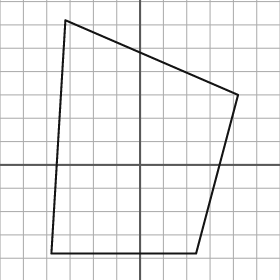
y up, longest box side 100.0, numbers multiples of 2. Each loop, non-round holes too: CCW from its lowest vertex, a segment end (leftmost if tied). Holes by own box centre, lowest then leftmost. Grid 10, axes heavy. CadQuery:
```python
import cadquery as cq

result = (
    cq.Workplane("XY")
    .moveTo(-38.0, -38.0)
    .lineTo(24.0, -38.0)
    .lineTo(42.0, 30.0)
    .lineTo(-32.0, 62.0)
    .close()
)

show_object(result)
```